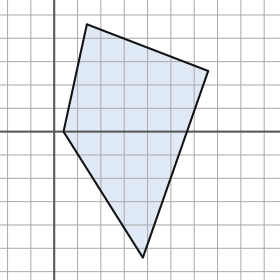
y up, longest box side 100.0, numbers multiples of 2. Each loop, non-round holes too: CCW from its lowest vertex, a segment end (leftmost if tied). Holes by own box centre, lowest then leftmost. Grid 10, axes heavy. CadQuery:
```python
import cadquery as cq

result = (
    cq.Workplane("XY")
    .moveTo(38.0, -54.0)
    .lineTo(66.0, 26.0)
    .lineTo(14.0, 46.0)
    .lineTo(4.0, 0.0)
    .close()
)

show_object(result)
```